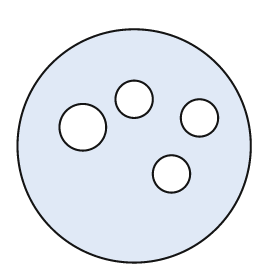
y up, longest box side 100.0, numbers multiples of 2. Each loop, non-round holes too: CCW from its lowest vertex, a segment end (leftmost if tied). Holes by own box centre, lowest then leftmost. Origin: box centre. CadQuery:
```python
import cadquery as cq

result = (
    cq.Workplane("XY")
    .moveTo(0.0, 0.0)
    .circle(50.0)
    .moveTo(16.0, -12.0)
    .circle(8.0)
    .moveTo(-22.0, 8.0)
    .circle(10.0)
    .moveTo(28.0, 12.0)
    .circle(8.0)
    .moveTo(0.0, 20.0)
    .circle(8.0)
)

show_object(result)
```